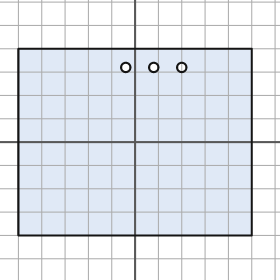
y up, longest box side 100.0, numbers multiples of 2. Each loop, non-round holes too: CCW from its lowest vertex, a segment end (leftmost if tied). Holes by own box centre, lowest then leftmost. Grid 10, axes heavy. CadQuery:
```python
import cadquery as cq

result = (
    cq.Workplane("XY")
    .moveTo(-50.0, -40.0)
    .lineTo(50.0, -40.0)
    .lineTo(50.0, 40.0)
    .lineTo(-50.0, 40.0)
    .close()
    .moveTo(-4.0, 32.0)
    .circle(2.0)
    .moveTo(8.0, 32.0)
    .circle(2.0)
    .moveTo(20.0, 32.0)
    .circle(2.0)
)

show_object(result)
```